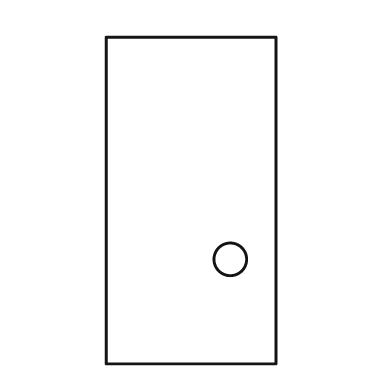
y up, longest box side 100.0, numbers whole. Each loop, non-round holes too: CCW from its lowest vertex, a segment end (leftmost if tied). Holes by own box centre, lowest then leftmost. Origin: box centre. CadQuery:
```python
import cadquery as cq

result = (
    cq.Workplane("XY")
    .moveTo(-26.0, -50.0)
    .lineTo(26.0, -50.0)
    .lineTo(26.0, 50.0)
    .lineTo(-26.0, 50.0)
    .close()
    .moveTo(12.0, -18.0)
    .circle(5.0)
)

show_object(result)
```